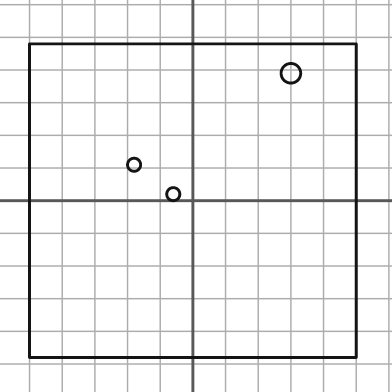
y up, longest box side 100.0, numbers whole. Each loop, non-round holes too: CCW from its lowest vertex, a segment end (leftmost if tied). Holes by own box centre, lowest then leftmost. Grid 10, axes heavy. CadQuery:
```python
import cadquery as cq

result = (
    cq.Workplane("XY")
    .moveTo(-50.0, -48.0)
    .lineTo(50.0, -48.0)
    .lineTo(50.0, 48.0)
    .lineTo(-50.0, 48.0)
    .close()
    .moveTo(-6.0, 2.0)
    .circle(2.0)
    .moveTo(-18.0, 11.0)
    .circle(2.0)
    .moveTo(30.0, 39.0)
    .circle(3.0)
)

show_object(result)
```